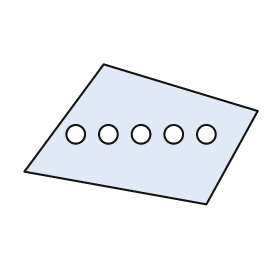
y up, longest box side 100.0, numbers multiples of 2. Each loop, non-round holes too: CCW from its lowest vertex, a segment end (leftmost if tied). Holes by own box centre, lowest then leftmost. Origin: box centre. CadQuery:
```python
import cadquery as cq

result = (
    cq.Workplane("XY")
    .moveTo(28.0, -30.0)
    .lineTo(50.0, 10.0)
    .lineTo(-16.0, 30.0)
    .lineTo(-50.0, -16.0)
    .close()
    .moveTo(-28.0, 0.0)
    .circle(4.0)
    .moveTo(-14.0, 0.0)
    .circle(4.0)
    .moveTo(0.0, 0.0)
    .circle(4.0)
    .moveTo(14.0, 0.0)
    .circle(4.0)
    .moveTo(28.0, 0.0)
    .circle(4.0)
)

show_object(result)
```